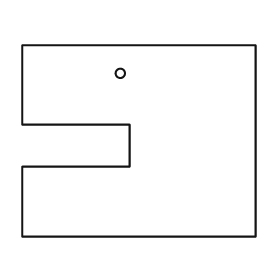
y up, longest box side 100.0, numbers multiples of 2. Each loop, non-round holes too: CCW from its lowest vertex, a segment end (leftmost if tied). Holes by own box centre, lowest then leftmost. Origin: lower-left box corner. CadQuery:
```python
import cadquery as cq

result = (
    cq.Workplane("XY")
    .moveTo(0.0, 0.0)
    .lineTo(100.0, 0.0)
    .lineTo(100.0, 82.0)
    .lineTo(0.0, 82.0)
    .lineTo(0.0, 48.0)
    .lineTo(46.0, 48.0)
    .lineTo(46.0, 30.0)
    .lineTo(0.0, 30.0)
    .close()
    .moveTo(42.0, 70.0)
    .circle(2.0)
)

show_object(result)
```